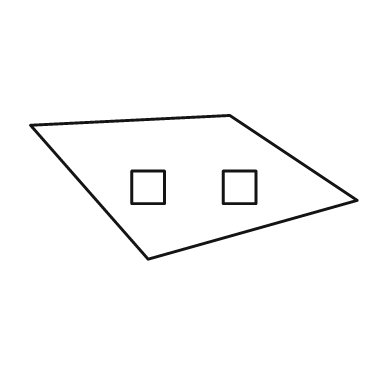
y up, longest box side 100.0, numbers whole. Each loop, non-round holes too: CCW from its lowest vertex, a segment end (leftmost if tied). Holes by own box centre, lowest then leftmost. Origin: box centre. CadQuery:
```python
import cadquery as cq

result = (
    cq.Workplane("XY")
    .moveTo(-14.0, -22.0)
    .lineTo(50.0, -4.0)
    .lineTo(11.0, 22.0)
    .lineTo(-50.0, 19.0)
    .close()
    .moveTo(-19.0, -5.0)
    .lineTo(-9.0, -5.0)
    .lineTo(-9.0, 5.0)
    .lineTo(-19.0, 5.0)
    .close()
    .moveTo(9.0, -5.0)
    .lineTo(19.0, -5.0)
    .lineTo(19.0, 5.0)
    .lineTo(9.0, 5.0)
    .close()
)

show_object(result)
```